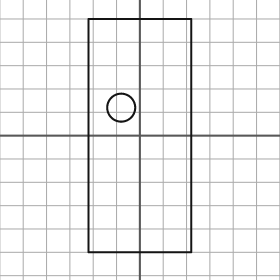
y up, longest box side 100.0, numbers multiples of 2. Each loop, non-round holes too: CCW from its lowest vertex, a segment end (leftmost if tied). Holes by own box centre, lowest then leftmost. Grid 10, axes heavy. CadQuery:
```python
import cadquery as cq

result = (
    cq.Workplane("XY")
    .moveTo(-22.0, -50.0)
    .lineTo(22.0, -50.0)
    .lineTo(22.0, 50.0)
    .lineTo(-22.0, 50.0)
    .close()
    .moveTo(-8.0, 12.0)
    .circle(6.0)
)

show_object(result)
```